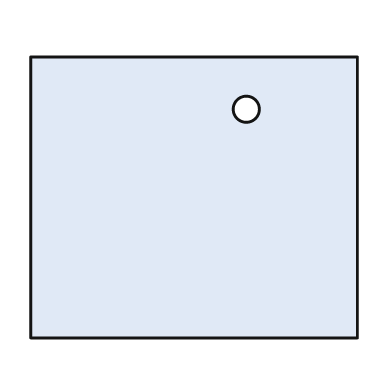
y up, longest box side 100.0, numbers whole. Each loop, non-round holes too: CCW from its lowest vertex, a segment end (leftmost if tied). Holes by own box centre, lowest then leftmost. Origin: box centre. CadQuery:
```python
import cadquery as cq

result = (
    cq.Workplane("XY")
    .moveTo(-50.0, -43.0)
    .lineTo(50.0, -43.0)
    .lineTo(50.0, 43.0)
    .lineTo(-50.0, 43.0)
    .close()
    .moveTo(16.0, 27.0)
    .circle(4.0)
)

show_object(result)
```